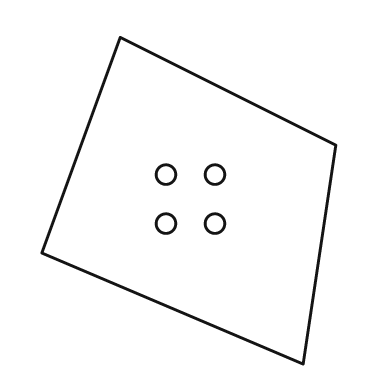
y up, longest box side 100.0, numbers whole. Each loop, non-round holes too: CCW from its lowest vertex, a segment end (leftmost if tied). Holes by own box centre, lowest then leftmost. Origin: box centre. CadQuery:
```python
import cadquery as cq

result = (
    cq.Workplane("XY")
    .moveTo(35.0, -50.0)
    .lineTo(45.0, 17.0)
    .lineTo(-21.0, 50.0)
    .lineTo(-45.0, -16.0)
    .close()
    .moveTo(-7.0, -7.0)
    .circle(3.0)
    .moveTo(8.0, -7.0)
    .circle(3.0)
    .moveTo(-7.0, 8.0)
    .circle(3.0)
    .moveTo(8.0, 8.0)
    .circle(3.0)
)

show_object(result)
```